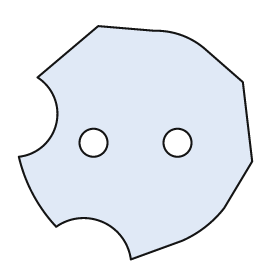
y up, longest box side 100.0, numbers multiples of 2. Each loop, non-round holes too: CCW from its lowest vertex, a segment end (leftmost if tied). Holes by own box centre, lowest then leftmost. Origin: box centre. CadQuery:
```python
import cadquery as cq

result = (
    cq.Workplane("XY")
    .moveTo(-2.0, -50.0)
    .lineTo(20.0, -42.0)
    .threePointArc((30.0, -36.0), (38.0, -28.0))
    .lineTo(50.0, -8.0)
    .lineTo(46.0, 26.0)
    .lineTo(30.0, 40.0)
    .threePointArc((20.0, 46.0), (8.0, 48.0))
    .lineTo(-16.0, 50.0)
    .lineTo(-42.0, 28.0)
    .threePointArc((-34.0, 8.0), (-50.0, -6.0))
    .threePointArc((-44.0, -22.0), (-34.0, -36.0))
    .threePointArc((-14.0, -34.0), (-2.0, -50.0))
    .close()
    .moveTo(-18.0, 0.0)
    .circle(6.0)
    .moveTo(18.0, 0.0)
    .circle(6.0)
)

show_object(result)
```